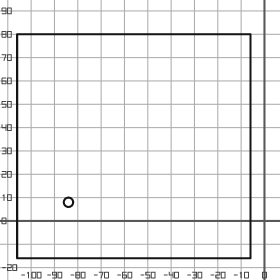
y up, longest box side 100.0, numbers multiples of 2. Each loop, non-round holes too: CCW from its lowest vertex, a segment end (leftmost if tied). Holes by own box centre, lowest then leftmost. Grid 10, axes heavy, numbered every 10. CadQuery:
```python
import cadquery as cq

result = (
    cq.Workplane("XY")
    .moveTo(-106.0, -16.0)
    .lineTo(-6.0, -16.0)
    .lineTo(-6.0, 80.0)
    .lineTo(-106.0, 80.0)
    .close()
    .moveTo(-84.0, 8.0)
    .circle(2.0)
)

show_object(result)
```